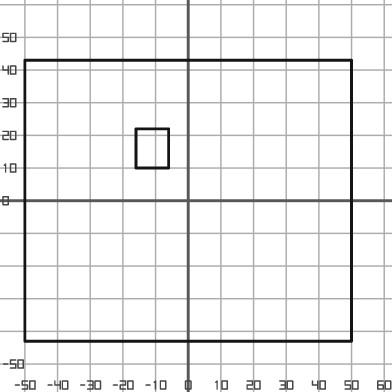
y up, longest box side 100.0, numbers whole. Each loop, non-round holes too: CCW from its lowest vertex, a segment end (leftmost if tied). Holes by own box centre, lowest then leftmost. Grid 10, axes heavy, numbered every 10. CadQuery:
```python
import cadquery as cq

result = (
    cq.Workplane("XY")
    .moveTo(-50.0, -43.0)
    .lineTo(50.0, -43.0)
    .lineTo(50.0, 43.0)
    .lineTo(-50.0, 43.0)
    .close()
    .moveTo(-16.0, 10.0)
    .lineTo(-6.0, 10.0)
    .lineTo(-6.0, 22.0)
    .lineTo(-16.0, 22.0)
    .close()
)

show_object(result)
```